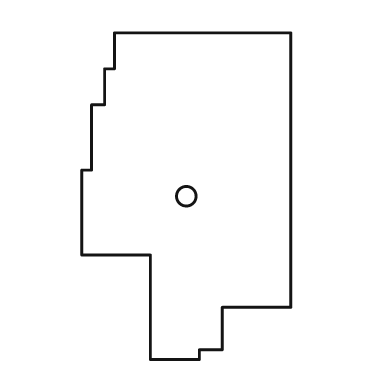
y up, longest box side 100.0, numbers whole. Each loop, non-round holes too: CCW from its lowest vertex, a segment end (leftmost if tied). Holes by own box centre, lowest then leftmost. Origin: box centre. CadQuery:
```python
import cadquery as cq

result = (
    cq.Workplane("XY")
    .moveTo(-11.0, -50.0)
    .lineTo(4.0, -50.0)
    .lineTo(4.0, -47.0)
    .lineTo(11.0, -47.0)
    .lineTo(11.0, -34.0)
    .lineTo(32.0, -34.0)
    .lineTo(32.0, 50.0)
    .lineTo(-22.0, 50.0)
    .lineTo(-22.0, 39.0)
    .lineTo(-25.0, 39.0)
    .lineTo(-25.0, 28.0)
    .lineTo(-29.0, 28.0)
    .lineTo(-29.0, 8.0)
    .lineTo(-32.0, 8.0)
    .lineTo(-32.0, -18.0)
    .lineTo(-11.0, -18.0)
    .close()
    .moveTo(0.0, 0.0)
    .circle(3.0)
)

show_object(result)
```